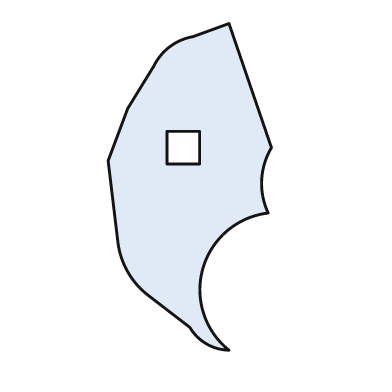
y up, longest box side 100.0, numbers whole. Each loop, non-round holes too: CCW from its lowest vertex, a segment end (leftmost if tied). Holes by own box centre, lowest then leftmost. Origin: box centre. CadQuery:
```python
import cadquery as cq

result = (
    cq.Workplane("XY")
    .moveTo(12.0, -50.0)
    .threePointArc((4.0, -25.0), (24.0, -8.0))
    .threePointArc((22.0, 2.0), (25.0, 12.0))
    .lineTo(12.0, 50.0)
    .lineTo(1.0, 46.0)
    .threePointArc((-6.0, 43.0), (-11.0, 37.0))
    .lineTo(-19.0, 24.0)
    .lineTo(-25.0, 8.0)
    .lineTo(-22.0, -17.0)
    .threePointArc((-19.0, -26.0), (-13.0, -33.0))
    .lineTo(0.0, -43.0)
    .threePointArc((5.0, -48.0), (12.0, -50.0))
    .close()
    .moveTo(-7.0, 7.0)
    .lineTo(3.0, 7.0)
    .lineTo(3.0, 17.0)
    .lineTo(-7.0, 17.0)
    .close()
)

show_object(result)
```